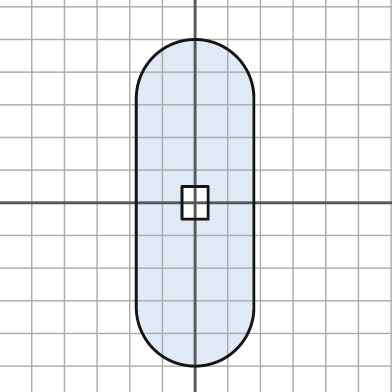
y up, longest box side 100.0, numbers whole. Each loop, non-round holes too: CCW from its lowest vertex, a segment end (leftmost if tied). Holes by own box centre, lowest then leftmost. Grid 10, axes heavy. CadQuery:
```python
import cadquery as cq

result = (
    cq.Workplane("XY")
    .moveTo(-18.0, -32.0)
    .threePointArc((0.0, -50.0), (18.0, -32.0))
    .lineTo(18.0, 32.0)
    .threePointArc((0.0, 50.0), (-18.0, 32.0))
    .close()
    .moveTo(-4.0, -5.0)
    .lineTo(4.0, -5.0)
    .lineTo(4.0, 5.0)
    .lineTo(-4.0, 5.0)
    .close()
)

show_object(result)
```